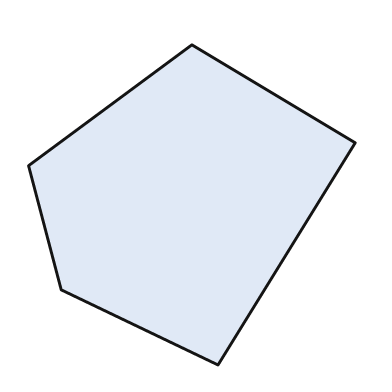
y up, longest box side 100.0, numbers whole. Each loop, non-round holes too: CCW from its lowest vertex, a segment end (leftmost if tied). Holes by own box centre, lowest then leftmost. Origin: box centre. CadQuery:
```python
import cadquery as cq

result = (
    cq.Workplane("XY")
    .moveTo(8.0, -49.0)
    .lineTo(50.0, 19.0)
    .lineTo(0.0, 49.0)
    .lineTo(-50.0, 12.0)
    .lineTo(-40.0, -26.0)
    .close()
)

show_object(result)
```